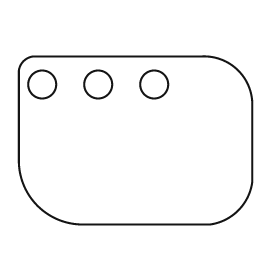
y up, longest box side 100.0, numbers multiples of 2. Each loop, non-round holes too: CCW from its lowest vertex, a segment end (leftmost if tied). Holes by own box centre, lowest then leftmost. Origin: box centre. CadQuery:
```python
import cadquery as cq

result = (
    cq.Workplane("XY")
    .moveTo(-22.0, -36.0)
    .lineTo(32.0, -36.0)
    .threePointArc((44.0, -30.0), (50.0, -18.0))
    .lineTo(50.0, 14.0)
    .threePointArc((44.0, 30.0), (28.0, 36.0))
    .lineTo(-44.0, 36.0)
    .threePointArc((-48.0, 34.0), (-50.0, 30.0))
    .lineTo(-50.0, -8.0)
    .threePointArc((-42.0, -28.0), (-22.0, -36.0))
    .close()
    .moveTo(-40.0, 24.0)
    .circle(6.0)
    .moveTo(-16.0, 24.0)
    .circle(6.0)
    .moveTo(8.0, 24.0)
    .circle(6.0)
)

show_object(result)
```